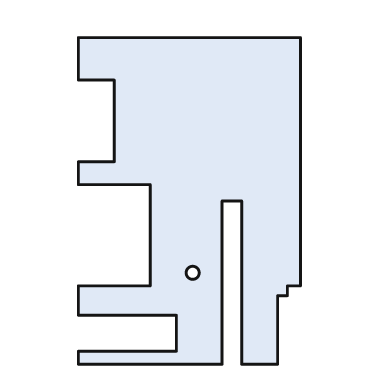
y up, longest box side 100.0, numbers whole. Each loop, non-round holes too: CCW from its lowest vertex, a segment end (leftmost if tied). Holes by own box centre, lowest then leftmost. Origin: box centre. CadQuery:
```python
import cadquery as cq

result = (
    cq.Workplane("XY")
    .moveTo(-34.0, -50.0)
    .lineTo(10.0, -50.0)
    .lineTo(10.0, 0.0)
    .lineTo(16.0, 0.0)
    .lineTo(16.0, -50.0)
    .lineTo(27.0, -50.0)
    .lineTo(27.0, -29.0)
    .lineTo(30.0, -29.0)
    .lineTo(30.0, -26.0)
    .lineTo(34.0, -26.0)
    .lineTo(34.0, 50.0)
    .lineTo(-34.0, 50.0)
    .lineTo(-34.0, 37.0)
    .lineTo(-23.0, 37.0)
    .lineTo(-23.0, 12.0)
    .lineTo(-34.0, 12.0)
    .lineTo(-34.0, 5.0)
    .lineTo(-12.0, 5.0)
    .lineTo(-12.0, -26.0)
    .lineTo(-34.0, -26.0)
    .lineTo(-34.0, -35.0)
    .lineTo(-4.0, -35.0)
    .lineTo(-4.0, -46.0)
    .lineTo(-34.0, -46.0)
    .close()
    .moveTo(1.0, -22.0)
    .circle(2.0)
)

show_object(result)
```